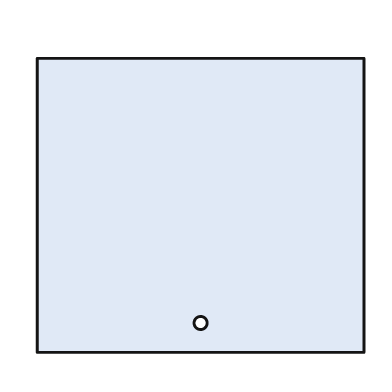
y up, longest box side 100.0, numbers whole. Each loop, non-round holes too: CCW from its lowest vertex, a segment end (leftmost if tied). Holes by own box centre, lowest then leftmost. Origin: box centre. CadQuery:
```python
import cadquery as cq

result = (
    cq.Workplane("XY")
    .moveTo(-50.0, -45.0)
    .lineTo(50.0, -45.0)
    .lineTo(50.0, 45.0)
    .lineTo(-50.0, 45.0)
    .close()
    .moveTo(0.0, -36.0)
    .circle(2.0)
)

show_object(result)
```